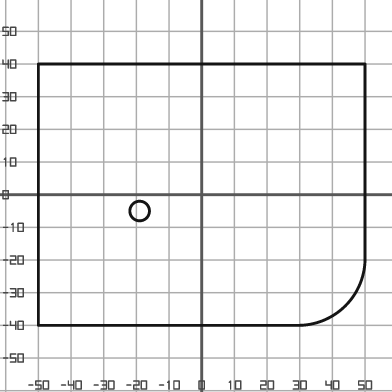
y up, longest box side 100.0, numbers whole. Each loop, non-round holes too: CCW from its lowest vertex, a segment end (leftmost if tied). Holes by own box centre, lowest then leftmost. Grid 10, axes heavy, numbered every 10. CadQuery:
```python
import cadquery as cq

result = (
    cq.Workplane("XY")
    .moveTo(-50.0, -40.0)
    .lineTo(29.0, -40.0)
    .threePointArc((44.0, -34.0), (50.0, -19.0))
    .lineTo(50.0, 40.0)
    .lineTo(-50.0, 40.0)
    .close()
    .moveTo(-19.0, -5.0)
    .circle(3.0)
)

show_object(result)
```